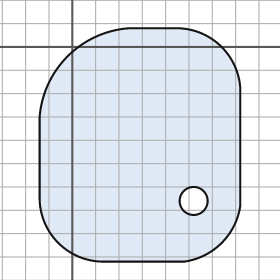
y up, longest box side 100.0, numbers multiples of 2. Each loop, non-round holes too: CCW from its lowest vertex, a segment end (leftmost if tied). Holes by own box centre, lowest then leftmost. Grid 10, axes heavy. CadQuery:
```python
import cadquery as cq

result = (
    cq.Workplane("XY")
    .moveTo(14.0, -92.0)
    .lineTo(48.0, -92.0)
    .threePointArc((64.0, -84.0), (72.0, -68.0))
    .lineTo(72.0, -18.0)
    .threePointArc((64.0, 0.0), (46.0, 8.0))
    .lineTo(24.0, 8.0)
    .threePointArc((-2.0, -4.0), (-14.0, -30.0))
    .lineTo(-14.0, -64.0)
    .threePointArc((-6.0, -84.0), (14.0, -92.0))
    .close()
    .moveTo(52.0, -66.0)
    .circle(6.0)
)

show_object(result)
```